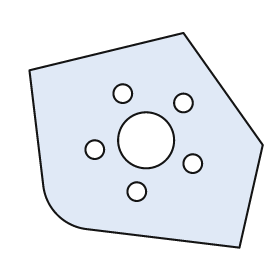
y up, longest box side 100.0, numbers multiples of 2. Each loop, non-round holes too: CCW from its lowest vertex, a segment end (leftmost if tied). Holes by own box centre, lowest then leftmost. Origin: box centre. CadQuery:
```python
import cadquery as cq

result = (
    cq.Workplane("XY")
    .moveTo(40.0, -46.0)
    .lineTo(50.0, -2.0)
    .lineTo(16.0, 46.0)
    .lineTo(-50.0, 30.0)
    .lineTo(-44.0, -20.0)
    .threePointArc((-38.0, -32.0), (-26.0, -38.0))
    .close()
    .moveTo(-4.0, -22.0)
    .circle(4.0)
    .moveTo(20.0, -10.0)
    .circle(4.0)
    .moveTo(-22.0, -4.0)
    .circle(4.0)
    .moveTo(0.0, 0.0)
    .circle(12.0)
    .moveTo(16.0, 16.0)
    .circle(4.0)
    .moveTo(-10.0, 20.0)
    .circle(4.0)
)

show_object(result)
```